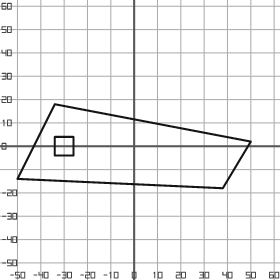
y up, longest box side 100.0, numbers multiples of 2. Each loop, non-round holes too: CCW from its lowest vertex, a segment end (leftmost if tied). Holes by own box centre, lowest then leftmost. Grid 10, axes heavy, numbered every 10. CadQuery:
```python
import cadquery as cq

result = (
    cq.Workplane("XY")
    .moveTo(38.0, -18.0)
    .lineTo(50.0, 2.0)
    .lineTo(-34.0, 18.0)
    .lineTo(-50.0, -14.0)
    .close()
    .moveTo(-34.0, -4.0)
    .lineTo(-26.0, -4.0)
    .lineTo(-26.0, 4.0)
    .lineTo(-34.0, 4.0)
    .close()
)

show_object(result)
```